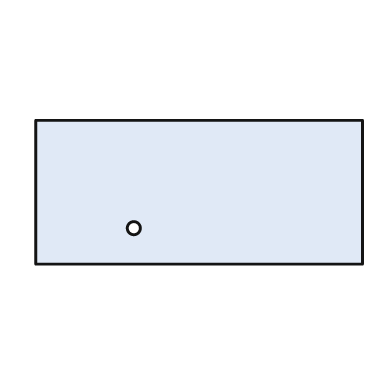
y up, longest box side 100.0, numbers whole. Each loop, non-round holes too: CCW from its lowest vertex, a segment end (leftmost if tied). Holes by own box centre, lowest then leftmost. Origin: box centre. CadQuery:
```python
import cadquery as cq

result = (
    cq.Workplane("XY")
    .moveTo(-50.0, -22.0)
    .lineTo(50.0, -22.0)
    .lineTo(50.0, 22.0)
    .lineTo(-50.0, 22.0)
    .close()
    .moveTo(-20.0, -11.0)
    .circle(2.0)
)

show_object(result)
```